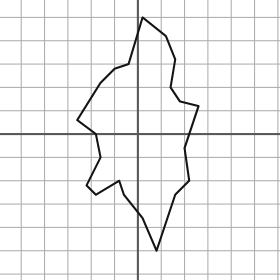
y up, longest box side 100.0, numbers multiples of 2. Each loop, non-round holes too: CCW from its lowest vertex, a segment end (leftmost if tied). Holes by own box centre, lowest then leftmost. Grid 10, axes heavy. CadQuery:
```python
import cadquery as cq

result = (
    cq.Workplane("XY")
    .moveTo(8.0, -50.0)
    .lineTo(16.0, -26.0)
    .lineTo(22.0, -20.0)
    .lineTo(20.0, -6.0)
    .lineTo(26.0, 12.0)
    .lineTo(18.0, 14.0)
    .lineTo(14.0, 20.0)
    .lineTo(16.0, 32.0)
    .lineTo(12.0, 42.0)
    .lineTo(2.0, 50.0)
    .lineTo(-4.0, 30.0)
    .lineTo(-10.0, 28.0)
    .lineTo(-16.0, 22.0)
    .lineTo(-26.0, 6.0)
    .lineTo(-18.0, 0.0)
    .lineTo(-16.0, -10.0)
    .lineTo(-22.0, -22.0)
    .lineTo(-18.0, -26.0)
    .lineTo(-8.0, -20.0)
    .lineTo(-6.0, -26.0)
    .lineTo(2.0, -36.0)
    .close()
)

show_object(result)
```